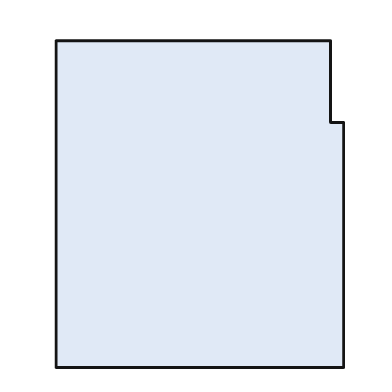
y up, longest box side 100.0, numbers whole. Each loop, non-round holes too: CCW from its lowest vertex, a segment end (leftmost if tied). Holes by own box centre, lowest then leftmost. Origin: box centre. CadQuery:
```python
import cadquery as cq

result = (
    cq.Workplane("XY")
    .moveTo(-44.0, -50.0)
    .lineTo(44.0, -50.0)
    .lineTo(44.0, 25.0)
    .lineTo(40.0, 25.0)
    .lineTo(40.0, 50.0)
    .lineTo(-44.0, 50.0)
    .close()
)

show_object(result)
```